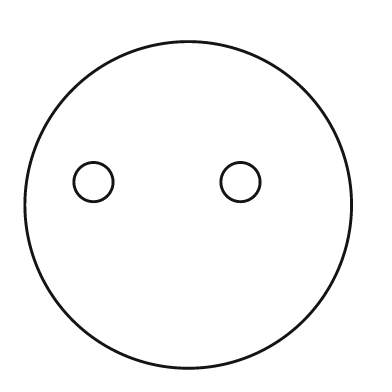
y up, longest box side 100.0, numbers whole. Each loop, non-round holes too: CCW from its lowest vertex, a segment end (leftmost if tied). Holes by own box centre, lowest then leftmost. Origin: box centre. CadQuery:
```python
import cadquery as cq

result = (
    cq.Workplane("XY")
    .moveTo(0.0, 0.0)
    .circle(50.0)
    .moveTo(-29.0, 7.0)
    .circle(6.0)
    .moveTo(16.0, 7.0)
    .circle(6.0)
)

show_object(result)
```